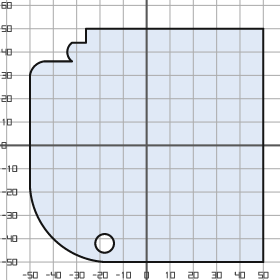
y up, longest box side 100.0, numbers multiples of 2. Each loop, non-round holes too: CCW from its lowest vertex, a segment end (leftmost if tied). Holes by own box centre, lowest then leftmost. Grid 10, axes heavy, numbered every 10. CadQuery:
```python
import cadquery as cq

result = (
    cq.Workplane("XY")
    .moveTo(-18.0, -50.0)
    .lineTo(50.0, -50.0)
    .lineTo(50.0, 50.0)
    .lineTo(-26.0, 50.0)
    .lineTo(-26.0, 44.0)
    .lineTo(-32.0, 44.0)
    .threePointArc((-34.0, 40.0), (-32.0, 36.0))
    .lineTo(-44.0, 36.0)
    .threePointArc((-48.0, 34.0), (-50.0, 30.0))
    .lineTo(-50.0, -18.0)
    .threePointArc((-40.0, -40.0), (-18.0, -50.0))
    .close()
    .moveTo(-18.0, -42.0)
    .circle(4.0)
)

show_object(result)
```